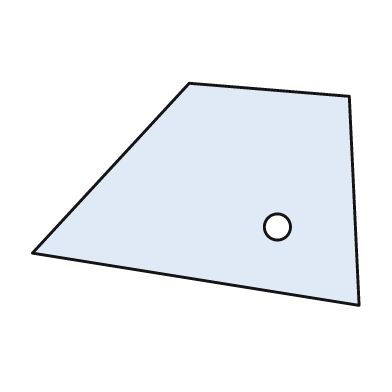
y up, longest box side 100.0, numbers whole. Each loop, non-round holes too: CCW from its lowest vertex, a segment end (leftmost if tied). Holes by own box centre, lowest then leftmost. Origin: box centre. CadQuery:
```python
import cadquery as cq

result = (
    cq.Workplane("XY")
    .moveTo(50.0, -34.0)
    .lineTo(47.0, 30.0)
    .lineTo(-2.0, 34.0)
    .lineTo(-50.0, -18.0)
    .close()
    .moveTo(25.0, -10.0)
    .circle(4.0)
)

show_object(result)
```